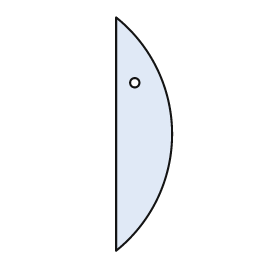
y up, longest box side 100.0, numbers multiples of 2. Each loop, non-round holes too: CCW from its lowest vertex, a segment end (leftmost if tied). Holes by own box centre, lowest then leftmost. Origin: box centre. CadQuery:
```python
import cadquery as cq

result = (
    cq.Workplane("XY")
    .moveTo(-12.0, -50.0)
    .threePointArc((12.0, 0.0), (-12.0, 50.0))
    .close()
    .moveTo(-4.0, 22.0)
    .circle(2.0)
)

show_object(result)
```